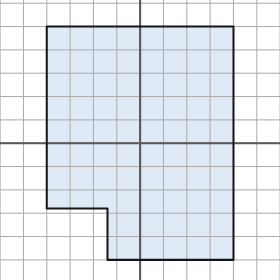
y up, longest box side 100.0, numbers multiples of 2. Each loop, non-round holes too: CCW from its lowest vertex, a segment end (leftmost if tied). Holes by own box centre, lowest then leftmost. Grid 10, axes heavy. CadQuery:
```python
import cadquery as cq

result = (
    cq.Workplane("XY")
    .moveTo(-14.0, -50.0)
    .lineTo(40.0, -50.0)
    .lineTo(40.0, 50.0)
    .lineTo(-40.0, 50.0)
    .lineTo(-40.0, -28.0)
    .lineTo(-14.0, -28.0)
    .close()
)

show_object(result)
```